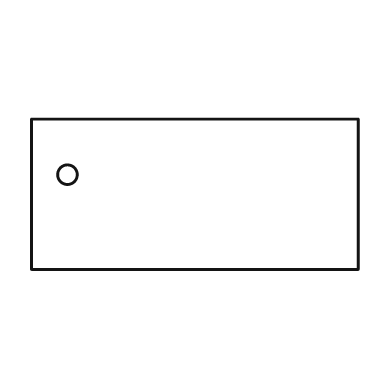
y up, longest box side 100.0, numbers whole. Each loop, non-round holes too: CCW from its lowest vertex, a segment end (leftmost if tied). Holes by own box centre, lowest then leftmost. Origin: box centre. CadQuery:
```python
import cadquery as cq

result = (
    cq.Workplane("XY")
    .moveTo(-50.0, -23.0)
    .lineTo(50.0, -23.0)
    .lineTo(50.0, 23.0)
    .lineTo(-50.0, 23.0)
    .close()
    .moveTo(-39.0, 6.0)
    .circle(3.0)
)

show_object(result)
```